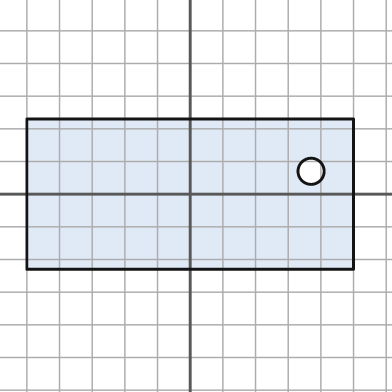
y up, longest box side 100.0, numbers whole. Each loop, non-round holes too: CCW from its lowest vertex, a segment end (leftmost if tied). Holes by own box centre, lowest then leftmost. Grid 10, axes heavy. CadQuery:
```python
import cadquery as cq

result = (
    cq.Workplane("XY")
    .moveTo(-50.0, -23.0)
    .lineTo(50.0, -23.0)
    .lineTo(50.0, 23.0)
    .lineTo(-50.0, 23.0)
    .close()
    .moveTo(37.0, 7.0)
    .circle(4.0)
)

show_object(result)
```